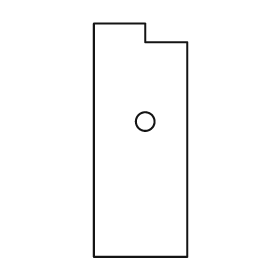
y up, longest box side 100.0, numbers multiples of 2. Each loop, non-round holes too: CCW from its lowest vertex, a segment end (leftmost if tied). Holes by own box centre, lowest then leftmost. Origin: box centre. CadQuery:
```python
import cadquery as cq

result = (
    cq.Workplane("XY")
    .moveTo(-20.0, -50.0)
    .lineTo(20.0, -50.0)
    .lineTo(20.0, 42.0)
    .lineTo(2.0, 42.0)
    .lineTo(2.0, 50.0)
    .lineTo(-20.0, 50.0)
    .close()
    .moveTo(2.0, 8.0)
    .circle(4.0)
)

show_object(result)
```